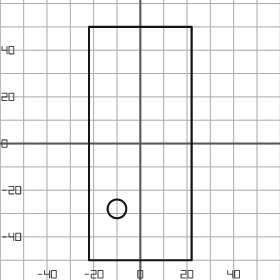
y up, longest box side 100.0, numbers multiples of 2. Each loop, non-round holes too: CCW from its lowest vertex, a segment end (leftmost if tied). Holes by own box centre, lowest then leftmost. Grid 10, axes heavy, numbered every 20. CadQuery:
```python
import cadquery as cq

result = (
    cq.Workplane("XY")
    .moveTo(-22.0, -50.0)
    .lineTo(22.0, -50.0)
    .lineTo(22.0, 50.0)
    .lineTo(-22.0, 50.0)
    .close()
    .moveTo(-10.0, -28.0)
    .circle(4.0)
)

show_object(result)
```